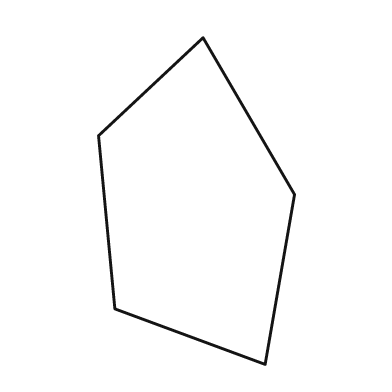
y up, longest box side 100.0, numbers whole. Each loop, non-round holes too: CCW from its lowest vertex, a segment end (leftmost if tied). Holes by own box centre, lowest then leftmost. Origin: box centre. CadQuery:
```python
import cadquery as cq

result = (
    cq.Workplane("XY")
    .moveTo(21.0, -50.0)
    .lineTo(30.0, 2.0)
    .lineTo(2.0, 50.0)
    .lineTo(-30.0, 20.0)
    .lineTo(-25.0, -33.0)
    .close()
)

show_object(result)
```